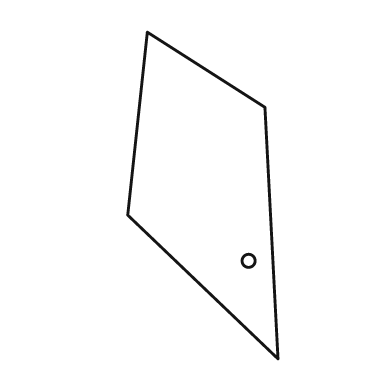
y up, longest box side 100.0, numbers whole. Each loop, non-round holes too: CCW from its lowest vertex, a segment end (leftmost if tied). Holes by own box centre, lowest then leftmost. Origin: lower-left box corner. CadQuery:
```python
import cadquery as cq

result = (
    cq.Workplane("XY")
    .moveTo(46.0, 0.0)
    .lineTo(42.0, 77.0)
    .lineTo(6.0, 100.0)
    .lineTo(0.0, 44.0)
    .close()
    .moveTo(37.0, 30.0)
    .circle(2.0)
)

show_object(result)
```